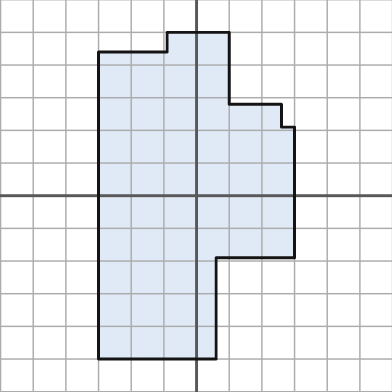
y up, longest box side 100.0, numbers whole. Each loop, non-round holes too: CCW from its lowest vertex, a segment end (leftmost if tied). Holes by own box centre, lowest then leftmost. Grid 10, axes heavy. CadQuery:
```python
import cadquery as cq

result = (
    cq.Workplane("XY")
    .moveTo(-30.0, -50.0)
    .lineTo(6.0, -50.0)
    .lineTo(6.0, -19.0)
    .lineTo(30.0, -19.0)
    .lineTo(30.0, 21.0)
    .lineTo(26.0, 21.0)
    .lineTo(26.0, 28.0)
    .lineTo(10.0, 28.0)
    .lineTo(10.0, 50.0)
    .lineTo(-9.0, 50.0)
    .lineTo(-9.0, 44.0)
    .lineTo(-30.0, 44.0)
    .close()
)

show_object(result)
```